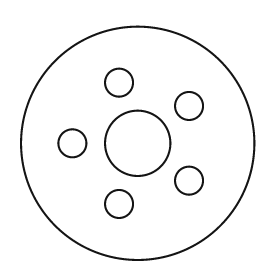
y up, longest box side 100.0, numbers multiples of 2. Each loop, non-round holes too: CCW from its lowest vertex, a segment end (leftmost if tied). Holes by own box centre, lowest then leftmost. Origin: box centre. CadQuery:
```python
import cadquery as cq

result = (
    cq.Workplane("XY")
    .moveTo(0.0, 0.0)
    .circle(50.0)
    .moveTo(-8.0, -26.0)
    .circle(6.0)
    .moveTo(22.0, -16.0)
    .circle(6.0)
    .moveTo(-28.0, 0.0)
    .circle(6.0)
    .moveTo(0.0, 0.0)
    .circle(14.0)
    .moveTo(22.0, 16.0)
    .circle(6.0)
    .moveTo(-8.0, 26.0)
    .circle(6.0)
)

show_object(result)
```